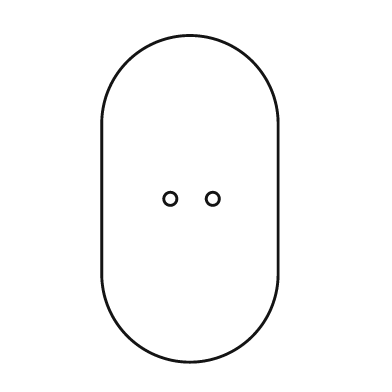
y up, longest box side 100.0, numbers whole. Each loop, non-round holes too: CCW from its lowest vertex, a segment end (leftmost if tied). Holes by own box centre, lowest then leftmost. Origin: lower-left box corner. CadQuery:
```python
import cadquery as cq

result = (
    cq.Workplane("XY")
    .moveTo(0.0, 27.0)
    .threePointArc((27.0, 0.0), (54.0, 27.0))
    .lineTo(54.0, 73.0)
    .threePointArc((27.0, 100.0), (0.0, 73.0))
    .close()
    .moveTo(21.0, 50.0)
    .circle(2.0)
    .moveTo(34.0, 50.0)
    .circle(2.0)
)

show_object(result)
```